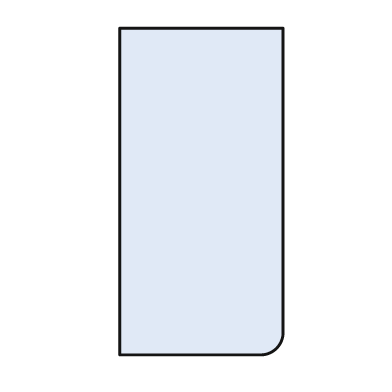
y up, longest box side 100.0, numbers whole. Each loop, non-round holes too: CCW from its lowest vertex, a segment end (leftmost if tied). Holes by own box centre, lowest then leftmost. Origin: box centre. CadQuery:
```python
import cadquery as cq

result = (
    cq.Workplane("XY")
    .moveTo(-25.0, -50.0)
    .lineTo(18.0, -50.0)
    .threePointArc((23.0, -48.0), (25.0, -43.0))
    .lineTo(25.0, 50.0)
    .lineTo(-25.0, 50.0)
    .close()
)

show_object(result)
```